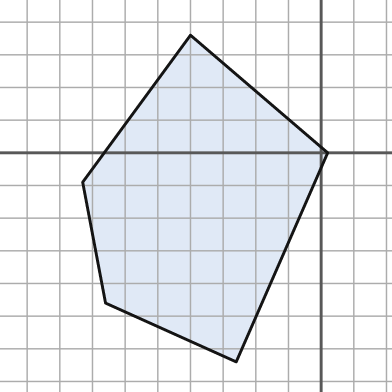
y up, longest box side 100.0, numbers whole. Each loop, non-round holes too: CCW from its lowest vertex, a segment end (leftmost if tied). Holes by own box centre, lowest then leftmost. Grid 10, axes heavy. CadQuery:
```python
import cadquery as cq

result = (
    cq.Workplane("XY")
    .moveTo(-26.0, -64.0)
    .lineTo(2.0, 0.0)
    .lineTo(-40.0, 36.0)
    .lineTo(-73.0, -9.0)
    .lineTo(-66.0, -46.0)
    .close()
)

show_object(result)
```